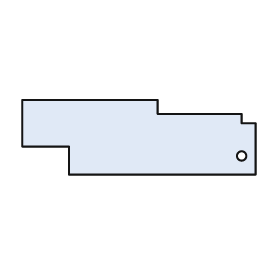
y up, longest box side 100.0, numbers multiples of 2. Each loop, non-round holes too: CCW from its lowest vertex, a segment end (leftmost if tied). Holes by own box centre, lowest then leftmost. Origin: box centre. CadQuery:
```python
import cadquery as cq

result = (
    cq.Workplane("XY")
    .moveTo(-30.0, -16.0)
    .lineTo(50.0, -16.0)
    .lineTo(50.0, 6.0)
    .lineTo(44.0, 6.0)
    .lineTo(44.0, 10.0)
    .lineTo(8.0, 10.0)
    .lineTo(8.0, 16.0)
    .lineTo(-50.0, 16.0)
    .lineTo(-50.0, -4.0)
    .lineTo(-30.0, -4.0)
    .close()
    .moveTo(44.0, -8.0)
    .circle(2.0)
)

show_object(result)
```